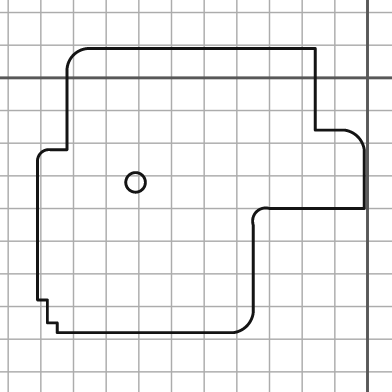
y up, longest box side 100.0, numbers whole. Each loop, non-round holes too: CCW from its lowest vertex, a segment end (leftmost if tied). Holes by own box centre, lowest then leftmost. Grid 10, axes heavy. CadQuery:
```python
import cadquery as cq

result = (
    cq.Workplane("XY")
    .moveTo(-95.0, -78.0)
    .lineTo(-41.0, -78.0)
    .threePointArc((-37.0, -76.0), (-35.0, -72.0))
    .lineTo(-35.0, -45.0)
    .threePointArc((-34.0, -41.0), (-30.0, -40.0))
    .lineTo(-1.0, -40.0)
    .lineTo(-1.0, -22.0)
    .threePointArc((-3.0, -18.0), (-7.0, -16.0))
    .lineTo(-16.0, -16.0)
    .lineTo(-16.0, 9.0)
    .lineTo(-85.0, 9.0)
    .threePointArc((-90.0, 7.0), (-92.0, 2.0))
    .lineTo(-92.0, -22.0)
    .lineTo(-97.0, -22.0)
    .threePointArc((-100.0, -23.0), (-101.0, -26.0))
    .lineTo(-101.0, -68.0)
    .lineTo(-98.0, -68.0)
    .lineTo(-98.0, -75.0)
    .lineTo(-95.0, -75.0)
    .close()
    .moveTo(-71.0, -32.0)
    .circle(3.0)
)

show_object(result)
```